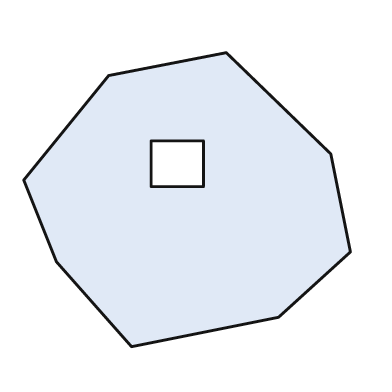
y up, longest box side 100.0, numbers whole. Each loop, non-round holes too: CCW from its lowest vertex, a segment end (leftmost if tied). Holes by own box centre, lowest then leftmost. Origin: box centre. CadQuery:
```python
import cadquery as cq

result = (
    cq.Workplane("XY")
    .moveTo(-17.0, -45.0)
    .lineTo(28.0, -36.0)
    .lineTo(50.0, -16.0)
    .lineTo(44.0, 14.0)
    .lineTo(12.0, 45.0)
    .lineTo(-24.0, 38.0)
    .lineTo(-50.0, 6.0)
    .lineTo(-40.0, -19.0)
    .close()
    .moveTo(-11.0, 4.0)
    .lineTo(5.0, 4.0)
    .lineTo(5.0, 18.0)
    .lineTo(-11.0, 18.0)
    .close()
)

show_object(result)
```